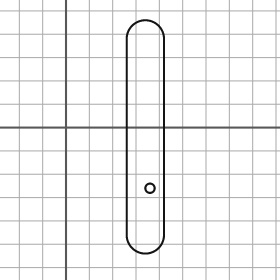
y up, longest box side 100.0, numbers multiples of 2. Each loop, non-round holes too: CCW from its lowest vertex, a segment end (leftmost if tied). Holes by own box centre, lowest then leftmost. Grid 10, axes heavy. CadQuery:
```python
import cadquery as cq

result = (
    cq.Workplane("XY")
    .moveTo(26.0, -46.0)
    .threePointArc((34.0, -54.0), (42.0, -46.0))
    .lineTo(42.0, 38.0)
    .threePointArc((34.0, 46.0), (26.0, 38.0))
    .close()
    .moveTo(36.0, -26.0)
    .circle(2.0)
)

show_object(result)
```